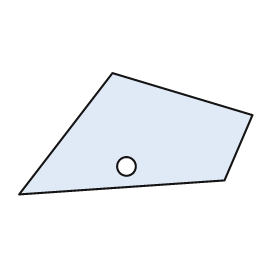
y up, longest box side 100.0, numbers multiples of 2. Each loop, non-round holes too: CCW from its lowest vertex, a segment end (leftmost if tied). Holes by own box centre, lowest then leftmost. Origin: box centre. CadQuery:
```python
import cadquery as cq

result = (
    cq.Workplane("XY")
    .moveTo(-50.0, -26.0)
    .lineTo(38.0, -20.0)
    .lineTo(50.0, 8.0)
    .lineTo(-10.0, 26.0)
    .close()
    .moveTo(-4.0, -14.0)
    .circle(4.0)
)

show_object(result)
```